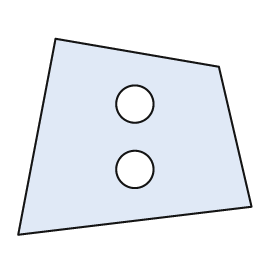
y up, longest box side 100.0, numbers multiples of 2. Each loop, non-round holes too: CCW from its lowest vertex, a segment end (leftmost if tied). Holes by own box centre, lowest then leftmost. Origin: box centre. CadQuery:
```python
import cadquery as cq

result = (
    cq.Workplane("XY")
    .moveTo(-50.0, -42.0)
    .lineTo(50.0, -30.0)
    .lineTo(36.0, 30.0)
    .lineTo(-34.0, 42.0)
    .close()
    .moveTo(0.0, -14.0)
    .circle(8.0)
    .moveTo(0.0, 14.0)
    .circle(8.0)
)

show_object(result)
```